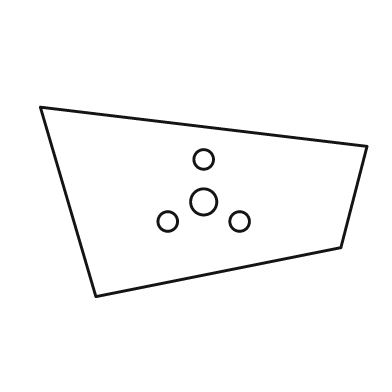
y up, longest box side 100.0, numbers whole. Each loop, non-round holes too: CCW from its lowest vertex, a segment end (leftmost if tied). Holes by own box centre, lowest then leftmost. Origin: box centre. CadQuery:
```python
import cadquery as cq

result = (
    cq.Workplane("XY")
    .moveTo(-33.0, -29.0)
    .lineTo(42.0, -14.0)
    .lineTo(50.0, 17.0)
    .lineTo(-50.0, 29.0)
    .close()
    .moveTo(-11.0, -6.0)
    .circle(3.0)
    .moveTo(11.0, -6.0)
    .circle(3.0)
    .moveTo(0.0, 0.0)
    .circle(4.0)
    .moveTo(0.0, 13.0)
    .circle(3.0)
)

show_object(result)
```